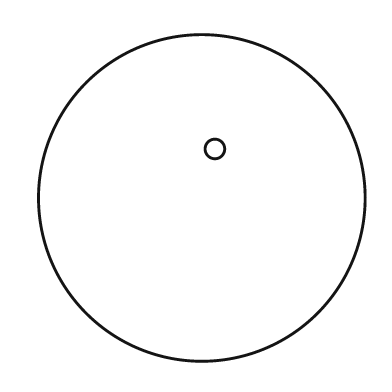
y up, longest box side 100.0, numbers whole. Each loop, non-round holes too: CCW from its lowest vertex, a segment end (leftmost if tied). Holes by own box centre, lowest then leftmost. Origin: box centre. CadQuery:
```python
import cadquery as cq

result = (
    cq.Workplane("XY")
    .moveTo(0.0, 0.0)
    .circle(50.0)
    .moveTo(4.0, 15.0)
    .circle(3.0)
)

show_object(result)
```